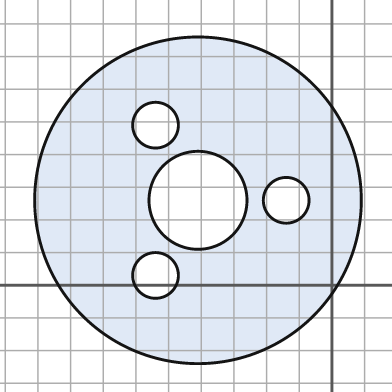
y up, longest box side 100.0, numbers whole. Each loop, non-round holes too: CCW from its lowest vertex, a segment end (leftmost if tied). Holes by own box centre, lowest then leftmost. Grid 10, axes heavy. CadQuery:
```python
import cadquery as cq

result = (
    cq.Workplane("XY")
    .moveTo(-41.0, 26.0)
    .circle(50.0)
    .moveTo(-54.0, 3.0)
    .circle(7.0)
    .moveTo(-41.0, 26.0)
    .circle(15.0)
    .moveTo(-14.0, 26.0)
    .circle(7.0)
    .moveTo(-54.0, 49.0)
    .circle(7.0)
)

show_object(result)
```